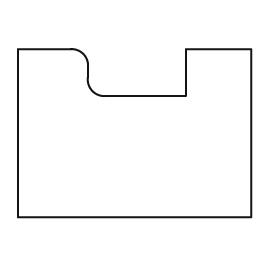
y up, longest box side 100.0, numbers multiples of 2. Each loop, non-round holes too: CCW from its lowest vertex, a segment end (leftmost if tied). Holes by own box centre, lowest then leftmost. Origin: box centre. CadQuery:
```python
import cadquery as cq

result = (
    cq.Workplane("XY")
    .moveTo(-50.0, -36.0)
    .lineTo(50.0, -36.0)
    .lineTo(50.0, 36.0)
    .lineTo(22.0, 36.0)
    .lineTo(22.0, 16.0)
    .lineTo(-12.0, 16.0)
    .threePointArc((-18.0, 18.0), (-20.0, 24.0))
    .lineTo(-20.0, 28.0)
    .threePointArc((-22.0, 34.0), (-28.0, 36.0))
    .lineTo(-50.0, 36.0)
    .close()
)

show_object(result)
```